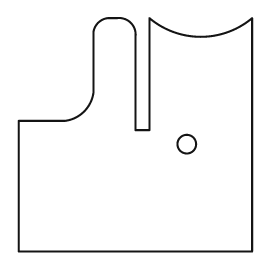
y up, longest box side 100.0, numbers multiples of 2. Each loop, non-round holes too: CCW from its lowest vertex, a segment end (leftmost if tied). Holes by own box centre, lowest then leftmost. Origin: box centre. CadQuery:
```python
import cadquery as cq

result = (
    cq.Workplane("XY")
    .moveTo(-50.0, -50.0)
    .lineTo(50.0, -50.0)
    .lineTo(50.0, 50.0)
    .threePointArc((28.0, 42.0), (6.0, 50.0))
    .lineTo(6.0, 2.0)
    .lineTo(0.0, 2.0)
    .lineTo(0.0, 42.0)
    .threePointArc((-2.0, 48.0), (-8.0, 50.0))
    .lineTo(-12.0, 50.0)
    .threePointArc((-16.0, 48.0), (-18.0, 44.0))
    .lineTo(-18.0, 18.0)
    .threePointArc((-22.0, 10.0), (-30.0, 6.0))
    .lineTo(-50.0, 6.0)
    .close()
    .moveTo(22.0, -4.0)
    .circle(4.0)
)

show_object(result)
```